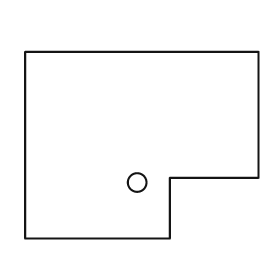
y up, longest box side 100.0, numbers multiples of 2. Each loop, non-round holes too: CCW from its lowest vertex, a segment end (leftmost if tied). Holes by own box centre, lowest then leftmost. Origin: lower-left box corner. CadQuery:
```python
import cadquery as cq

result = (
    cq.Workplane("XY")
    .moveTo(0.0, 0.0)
    .lineTo(62.0, 0.0)
    .lineTo(62.0, 26.0)
    .lineTo(100.0, 26.0)
    .lineTo(100.0, 80.0)
    .lineTo(0.0, 80.0)
    .close()
    .moveTo(48.0, 24.0)
    .circle(4.0)
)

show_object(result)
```